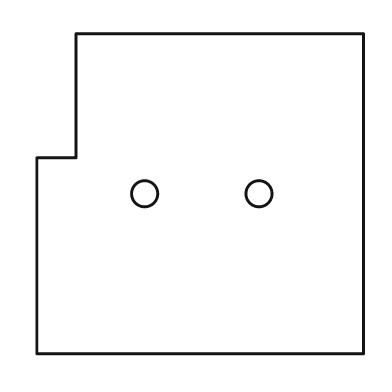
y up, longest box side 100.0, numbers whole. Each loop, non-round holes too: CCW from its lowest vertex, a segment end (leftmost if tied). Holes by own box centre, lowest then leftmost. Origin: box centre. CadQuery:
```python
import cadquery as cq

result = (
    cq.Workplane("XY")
    .moveTo(-50.0, -49.0)
    .lineTo(50.0, -49.0)
    .lineTo(50.0, 49.0)
    .lineTo(-38.0, 49.0)
    .lineTo(-38.0, 11.0)
    .lineTo(-50.0, 11.0)
    .close()
    .moveTo(-17.0, 0.0)
    .circle(4.0)
    .moveTo(18.0, 0.0)
    .circle(4.0)
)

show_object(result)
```